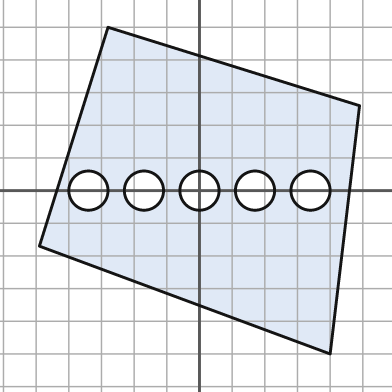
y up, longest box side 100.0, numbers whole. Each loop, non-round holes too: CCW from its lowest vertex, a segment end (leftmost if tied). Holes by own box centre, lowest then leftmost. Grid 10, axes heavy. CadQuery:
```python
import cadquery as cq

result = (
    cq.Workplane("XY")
    .moveTo(40.0, -50.0)
    .lineTo(49.0, 26.0)
    .lineTo(-28.0, 50.0)
    .lineTo(-49.0, -17.0)
    .close()
    .moveTo(-34.0, 0.0)
    .circle(6.0)
    .moveTo(-17.0, 0.0)
    .circle(6.0)
    .moveTo(0.0, 0.0)
    .circle(6.0)
    .moveTo(17.0, 0.0)
    .circle(6.0)
    .moveTo(34.0, 0.0)
    .circle(6.0)
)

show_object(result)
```